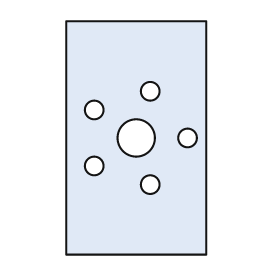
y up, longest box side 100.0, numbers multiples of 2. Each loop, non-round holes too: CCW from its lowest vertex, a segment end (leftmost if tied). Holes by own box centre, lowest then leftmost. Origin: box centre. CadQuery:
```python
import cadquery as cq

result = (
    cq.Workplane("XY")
    .moveTo(-30.0, -50.0)
    .lineTo(30.0, -50.0)
    .lineTo(30.0, 50.0)
    .lineTo(-30.0, 50.0)
    .close()
    .moveTo(6.0, -20.0)
    .circle(4.0)
    .moveTo(-18.0, -12.0)
    .circle(4.0)
    .moveTo(0.0, 0.0)
    .circle(8.0)
    .moveTo(22.0, 0.0)
    .circle(4.0)
    .moveTo(-18.0, 12.0)
    .circle(4.0)
    .moveTo(6.0, 20.0)
    .circle(4.0)
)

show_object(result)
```